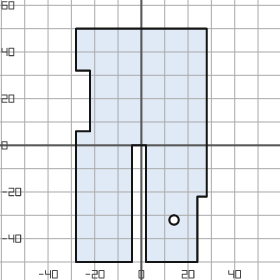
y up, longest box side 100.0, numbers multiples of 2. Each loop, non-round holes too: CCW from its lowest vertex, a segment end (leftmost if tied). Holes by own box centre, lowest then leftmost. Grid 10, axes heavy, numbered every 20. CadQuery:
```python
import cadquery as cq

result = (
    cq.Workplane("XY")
    .moveTo(-28.0, -50.0)
    .lineTo(-4.0, -50.0)
    .lineTo(-4.0, 0.0)
    .lineTo(2.0, 0.0)
    .lineTo(2.0, -50.0)
    .lineTo(24.0, -50.0)
    .lineTo(24.0, -22.0)
    .lineTo(28.0, -22.0)
    .lineTo(28.0, 50.0)
    .lineTo(-28.0, 50.0)
    .lineTo(-28.0, 32.0)
    .lineTo(-22.0, 32.0)
    .lineTo(-22.0, 6.0)
    .lineTo(-28.0, 6.0)
    .close()
    .moveTo(14.0, -32.0)
    .circle(2.0)
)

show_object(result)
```